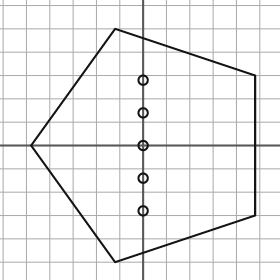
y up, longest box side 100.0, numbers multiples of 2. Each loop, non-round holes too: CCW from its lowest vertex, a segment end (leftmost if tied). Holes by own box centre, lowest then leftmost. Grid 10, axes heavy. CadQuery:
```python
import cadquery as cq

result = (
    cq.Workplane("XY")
    .moveTo(-12.0, -50.0)
    .lineTo(48.0, -30.0)
    .lineTo(48.0, 30.0)
    .lineTo(-12.0, 50.0)
    .lineTo(-48.0, 0.0)
    .close()
    .moveTo(0.0, -28.0)
    .circle(2.0)
    .moveTo(0.0, -14.0)
    .circle(2.0)
    .moveTo(0.0, 0.0)
    .circle(2.0)
    .moveTo(0.0, 14.0)
    .circle(2.0)
    .moveTo(0.0, 28.0)
    .circle(2.0)
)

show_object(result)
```